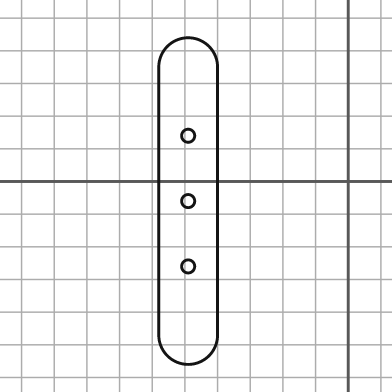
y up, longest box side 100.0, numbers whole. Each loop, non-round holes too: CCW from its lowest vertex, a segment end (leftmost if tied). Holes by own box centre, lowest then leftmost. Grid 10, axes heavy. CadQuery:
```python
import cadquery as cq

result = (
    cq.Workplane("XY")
    .moveTo(-58.0, -47.0)
    .threePointArc((-49.0, -56.0), (-40.0, -47.0))
    .lineTo(-40.0, 35.0)
    .threePointArc((-49.0, 44.0), (-58.0, 35.0))
    .close()
    .moveTo(-49.0, -26.0)
    .circle(2.0)
    .moveTo(-49.0, -6.0)
    .circle(2.0)
    .moveTo(-49.0, 14.0)
    .circle(2.0)
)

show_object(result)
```